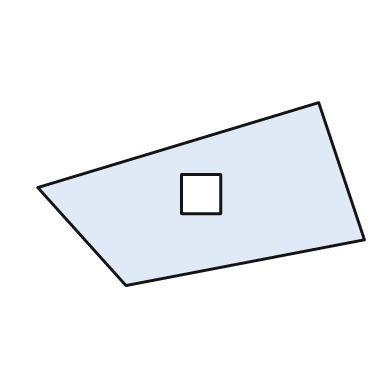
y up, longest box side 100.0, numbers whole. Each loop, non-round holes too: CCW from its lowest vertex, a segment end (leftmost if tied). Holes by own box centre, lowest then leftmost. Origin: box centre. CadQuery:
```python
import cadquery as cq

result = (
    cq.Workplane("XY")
    .moveTo(-23.0, -28.0)
    .lineTo(50.0, -14.0)
    .lineTo(36.0, 28.0)
    .lineTo(-50.0, 2.0)
    .close()
    .moveTo(-6.0, -6.0)
    .lineTo(6.0, -6.0)
    .lineTo(6.0, 6.0)
    .lineTo(-6.0, 6.0)
    .close()
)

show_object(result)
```